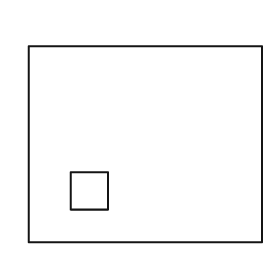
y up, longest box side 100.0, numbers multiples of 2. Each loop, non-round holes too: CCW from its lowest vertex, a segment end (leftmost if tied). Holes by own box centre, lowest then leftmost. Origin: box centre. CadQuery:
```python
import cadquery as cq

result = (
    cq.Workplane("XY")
    .moveTo(-50.0, -42.0)
    .lineTo(50.0, -42.0)
    .lineTo(50.0, 42.0)
    .lineTo(-50.0, 42.0)
    .close()
    .moveTo(-32.0, -28.0)
    .lineTo(-16.0, -28.0)
    .lineTo(-16.0, -12.0)
    .lineTo(-32.0, -12.0)
    .close()
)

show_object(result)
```